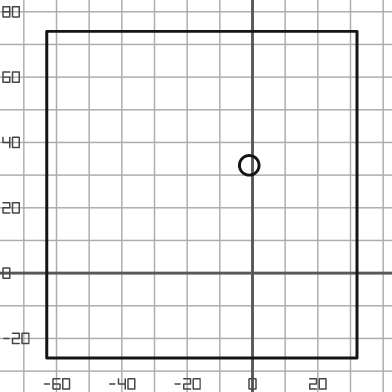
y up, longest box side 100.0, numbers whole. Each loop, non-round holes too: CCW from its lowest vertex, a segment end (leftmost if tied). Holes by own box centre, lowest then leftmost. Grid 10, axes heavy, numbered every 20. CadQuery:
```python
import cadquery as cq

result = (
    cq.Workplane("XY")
    .moveTo(-63.0, -26.0)
    .lineTo(32.0, -26.0)
    .lineTo(32.0, 74.0)
    .lineTo(-63.0, 74.0)
    .close()
    .moveTo(-1.0, 33.0)
    .circle(3.0)
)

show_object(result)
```